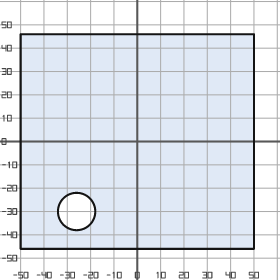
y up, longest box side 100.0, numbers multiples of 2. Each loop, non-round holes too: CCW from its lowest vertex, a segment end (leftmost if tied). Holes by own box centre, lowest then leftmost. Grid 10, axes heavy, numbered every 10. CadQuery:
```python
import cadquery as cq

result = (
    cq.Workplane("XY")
    .moveTo(-50.0, -46.0)
    .lineTo(50.0, -46.0)
    .lineTo(50.0, 46.0)
    .lineTo(-50.0, 46.0)
    .close()
    .moveTo(-26.0, -30.0)
    .circle(8.0)
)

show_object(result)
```